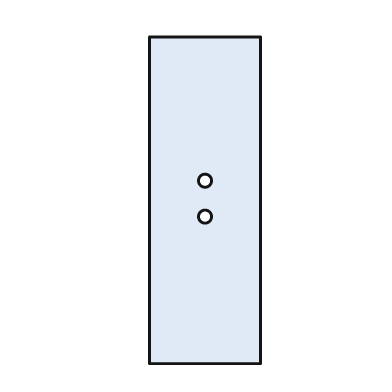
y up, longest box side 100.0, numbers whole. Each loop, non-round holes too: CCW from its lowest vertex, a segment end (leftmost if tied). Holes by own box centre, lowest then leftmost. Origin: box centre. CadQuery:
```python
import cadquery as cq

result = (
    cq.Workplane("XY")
    .moveTo(-17.0, -50.0)
    .lineTo(17.0, -50.0)
    .lineTo(17.0, 50.0)
    .lineTo(-17.0, 50.0)
    .close()
    .moveTo(0.0, -5.0)
    .circle(2.0)
    .moveTo(0.0, 6.0)
    .circle(2.0)
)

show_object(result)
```